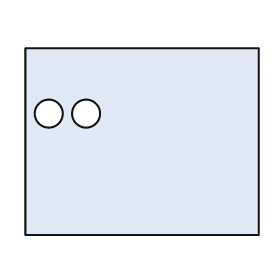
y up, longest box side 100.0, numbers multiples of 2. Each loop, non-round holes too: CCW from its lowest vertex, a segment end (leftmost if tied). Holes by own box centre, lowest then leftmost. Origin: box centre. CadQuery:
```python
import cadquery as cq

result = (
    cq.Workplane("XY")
    .moveTo(-50.0, -40.0)
    .lineTo(50.0, -40.0)
    .lineTo(50.0, 40.0)
    .lineTo(-50.0, 40.0)
    .close()
    .moveTo(-40.0, 12.0)
    .circle(6.0)
    .moveTo(-24.0, 12.0)
    .circle(6.0)
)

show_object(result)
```